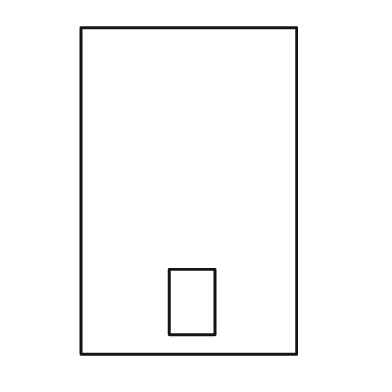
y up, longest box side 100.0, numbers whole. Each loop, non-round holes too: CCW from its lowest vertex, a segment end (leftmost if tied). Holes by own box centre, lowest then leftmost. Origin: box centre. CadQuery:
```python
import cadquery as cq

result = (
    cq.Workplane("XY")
    .moveTo(-33.0, -50.0)
    .lineTo(33.0, -50.0)
    .lineTo(33.0, 50.0)
    .lineTo(-33.0, 50.0)
    .close()
    .moveTo(-6.0, -44.0)
    .lineTo(8.0, -44.0)
    .lineTo(8.0, -24.0)
    .lineTo(-6.0, -24.0)
    .close()
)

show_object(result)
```